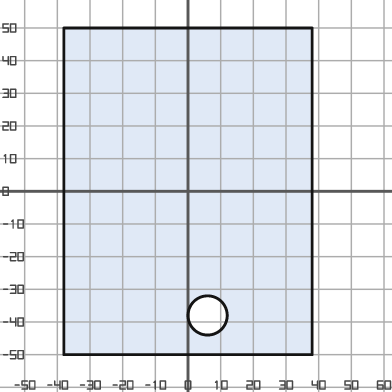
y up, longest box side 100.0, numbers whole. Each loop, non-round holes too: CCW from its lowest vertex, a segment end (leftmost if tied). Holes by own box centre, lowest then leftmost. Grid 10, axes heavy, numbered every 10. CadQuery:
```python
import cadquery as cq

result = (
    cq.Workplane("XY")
    .moveTo(-38.0, -50.0)
    .lineTo(38.0, -50.0)
    .lineTo(38.0, 50.0)
    .lineTo(-38.0, 50.0)
    .close()
    .moveTo(6.0, -38.0)
    .circle(6.0)
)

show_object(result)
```